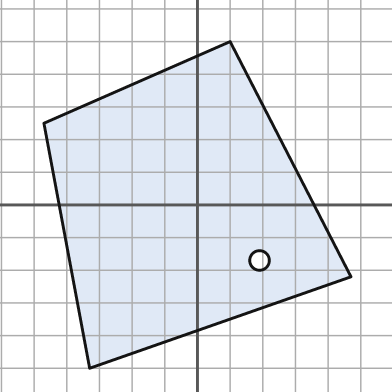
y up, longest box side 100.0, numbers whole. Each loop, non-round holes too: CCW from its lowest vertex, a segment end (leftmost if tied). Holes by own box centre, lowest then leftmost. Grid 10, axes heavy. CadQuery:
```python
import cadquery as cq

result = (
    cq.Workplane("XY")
    .moveTo(-33.0, -50.0)
    .lineTo(47.0, -22.0)
    .lineTo(10.0, 50.0)
    .lineTo(-47.0, 25.0)
    .close()
    .moveTo(19.0, -17.0)
    .circle(3.0)
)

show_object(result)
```